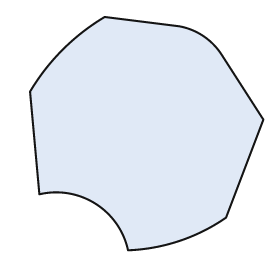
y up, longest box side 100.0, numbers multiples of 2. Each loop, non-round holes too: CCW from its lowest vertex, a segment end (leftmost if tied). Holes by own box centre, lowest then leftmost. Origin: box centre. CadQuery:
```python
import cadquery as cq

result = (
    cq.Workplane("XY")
    .moveTo(-8.0, -50.0)
    .threePointArc((14.0, -46.0), (34.0, -36.0))
    .lineTo(50.0, 6.0)
    .lineTo(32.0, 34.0)
    .threePointArc((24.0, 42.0), (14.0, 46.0))
    .lineTo(-18.0, 50.0)
    .threePointArc((-36.0, 36.0), (-50.0, 18.0))
    .lineTo(-46.0, -26.0)
    .threePointArc((-22.0, -30.0), (-8.0, -50.0))
    .close()
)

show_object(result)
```